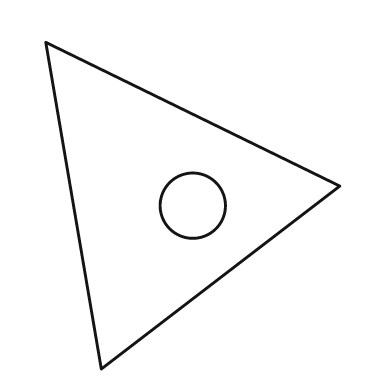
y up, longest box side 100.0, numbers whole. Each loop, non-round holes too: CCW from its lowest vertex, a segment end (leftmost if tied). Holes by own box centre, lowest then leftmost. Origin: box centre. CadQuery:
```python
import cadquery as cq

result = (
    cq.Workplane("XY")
    .moveTo(-28.0, -50.0)
    .lineTo(45.0, 6.0)
    .lineTo(-45.0, 50.0)
    .close()
    .moveTo(0.0, 0.0)
    .circle(10.0)
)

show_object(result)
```